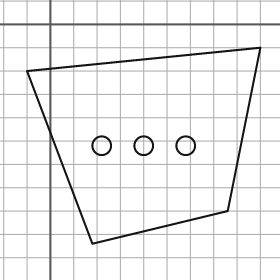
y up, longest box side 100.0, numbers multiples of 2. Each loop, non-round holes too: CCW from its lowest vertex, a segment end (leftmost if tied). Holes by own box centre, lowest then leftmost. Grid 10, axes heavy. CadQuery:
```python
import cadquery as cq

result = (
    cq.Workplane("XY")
    .moveTo(18.0, -94.0)
    .lineTo(76.0, -80.0)
    .lineTo(90.0, -10.0)
    .lineTo(-10.0, -20.0)
    .close()
    .moveTo(22.0, -52.0)
    .circle(4.0)
    .moveTo(40.0, -52.0)
    .circle(4.0)
    .moveTo(58.0, -52.0)
    .circle(4.0)
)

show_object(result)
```